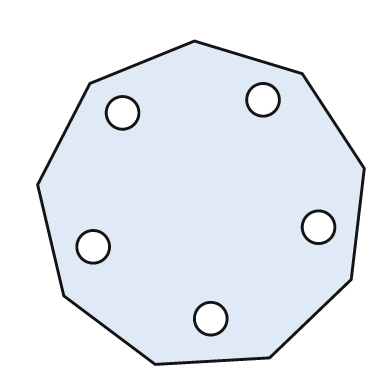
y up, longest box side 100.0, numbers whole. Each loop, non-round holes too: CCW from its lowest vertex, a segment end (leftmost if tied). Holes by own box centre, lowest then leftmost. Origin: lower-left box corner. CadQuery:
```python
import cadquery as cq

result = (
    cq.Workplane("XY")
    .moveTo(36.0, 0.0)
    .lineTo(71.0, 2.0)
    .lineTo(96.0, 26.0)
    .lineTo(100.0, 60.0)
    .lineTo(81.0, 89.0)
    .lineTo(48.0, 99.0)
    .lineTo(16.0, 86.0)
    .lineTo(0.0, 55.0)
    .lineTo(8.0, 21.0)
    .close()
    .moveTo(53.0, 14.0)
    .circle(5.0)
    .moveTo(17.0, 36.0)
    .circle(5.0)
    .moveTo(86.0, 42.0)
    .circle(5.0)
    .moveTo(26.0, 77.0)
    .circle(5.0)
    .moveTo(69.0, 81.0)
    .circle(5.0)
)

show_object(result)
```